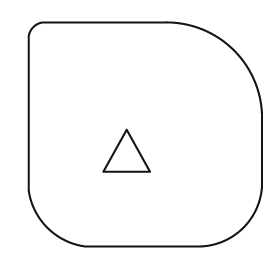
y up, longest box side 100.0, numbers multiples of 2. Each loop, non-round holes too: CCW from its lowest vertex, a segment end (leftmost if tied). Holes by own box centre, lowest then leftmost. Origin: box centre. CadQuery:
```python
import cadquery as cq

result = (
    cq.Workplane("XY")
    .moveTo(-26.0, -48.0)
    .lineTo(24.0, -48.0)
    .threePointArc((42.0, -40.0), (50.0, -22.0))
    .lineTo(50.0, 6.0)
    .threePointArc((38.0, 36.0), (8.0, 48.0))
    .lineTo(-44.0, 48.0)
    .threePointArc((-48.0, 46.0), (-50.0, 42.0))
    .lineTo(-50.0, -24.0)
    .threePointArc((-42.0, -40.0), (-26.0, -48.0))
    .close()
    .moveTo(-18.0, -16.0)
    .lineTo(2.0, -16.0)
    .lineTo(-8.0, 2.0)
    .close()
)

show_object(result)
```